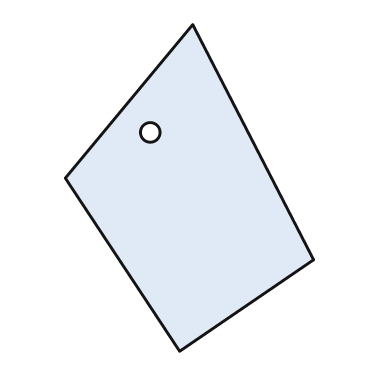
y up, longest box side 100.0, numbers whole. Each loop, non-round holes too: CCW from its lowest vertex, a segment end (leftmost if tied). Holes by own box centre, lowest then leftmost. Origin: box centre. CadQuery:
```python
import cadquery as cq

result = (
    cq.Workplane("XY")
    .moveTo(-3.0, -50.0)
    .lineTo(38.0, -22.0)
    .lineTo(1.0, 50.0)
    .lineTo(-38.0, 3.0)
    .close()
    .moveTo(-12.0, 17.0)
    .circle(3.0)
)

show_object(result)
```